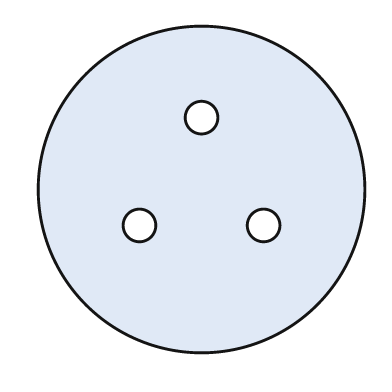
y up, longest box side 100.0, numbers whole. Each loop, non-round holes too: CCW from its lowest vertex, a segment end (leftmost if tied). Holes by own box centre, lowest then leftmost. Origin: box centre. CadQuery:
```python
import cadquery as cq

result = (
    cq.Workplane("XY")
    .moveTo(0.0, 0.0)
    .circle(50.0)
    .moveTo(-19.0, -11.0)
    .circle(5.0)
    .moveTo(19.0, -11.0)
    .circle(5.0)
    .moveTo(0.0, 22.0)
    .circle(5.0)
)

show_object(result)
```